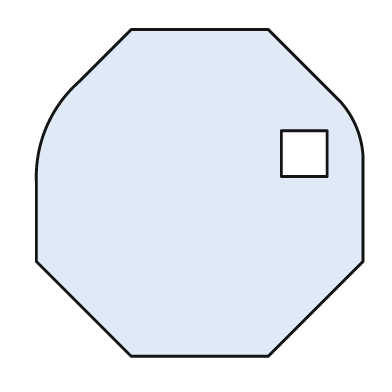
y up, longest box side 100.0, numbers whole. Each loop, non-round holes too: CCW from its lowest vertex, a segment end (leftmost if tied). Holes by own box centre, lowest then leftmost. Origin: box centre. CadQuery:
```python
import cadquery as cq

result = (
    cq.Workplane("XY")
    .moveTo(-21.0, -50.0)
    .lineTo(21.0, -50.0)
    .lineTo(50.0, -21.0)
    .lineTo(50.0, 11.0)
    .threePointArc((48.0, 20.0), (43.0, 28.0))
    .lineTo(21.0, 50.0)
    .lineTo(-21.0, 50.0)
    .lineTo(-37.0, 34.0)
    .threePointArc((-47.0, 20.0), (-50.0, 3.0))
    .lineTo(-50.0, -21.0)
    .close()
    .moveTo(25.0, 5.0)
    .lineTo(39.0, 5.0)
    .lineTo(39.0, 19.0)
    .lineTo(25.0, 19.0)
    .close()
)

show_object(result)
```